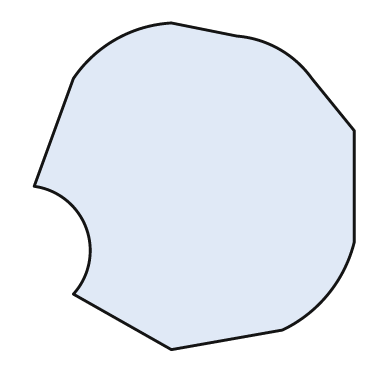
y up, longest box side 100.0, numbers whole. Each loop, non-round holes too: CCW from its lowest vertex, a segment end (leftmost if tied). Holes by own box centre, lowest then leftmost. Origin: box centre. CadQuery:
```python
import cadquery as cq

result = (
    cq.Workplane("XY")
    .moveTo(-7.0, -50.0)
    .lineTo(27.0, -44.0)
    .threePointArc((41.0, -33.0), (49.0, -17.0))
    .lineTo(49.0, 17.0)
    .lineTo(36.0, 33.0)
    .threePointArc((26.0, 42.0), (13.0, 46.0))
    .lineTo(-7.0, 50.0)
    .threePointArc((-24.0, 45.0), (-37.0, 33.0))
    .lineTo(-49.0, 0.0)
    .threePointArc((-33.0, -13.0), (-37.0, -33.0))
    .close()
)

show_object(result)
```